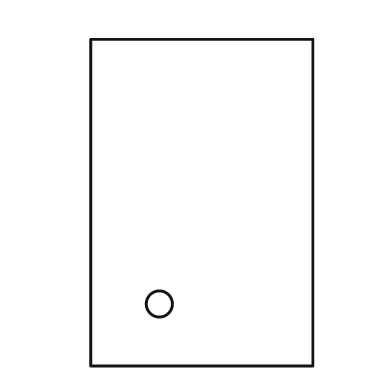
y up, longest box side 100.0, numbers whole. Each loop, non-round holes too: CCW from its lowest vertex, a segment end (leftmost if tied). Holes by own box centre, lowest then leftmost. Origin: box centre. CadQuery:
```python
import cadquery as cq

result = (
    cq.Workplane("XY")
    .moveTo(-34.0, -50.0)
    .lineTo(34.0, -50.0)
    .lineTo(34.0, 50.0)
    .lineTo(-34.0, 50.0)
    .close()
    .moveTo(-13.0, -31.0)
    .circle(4.0)
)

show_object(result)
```